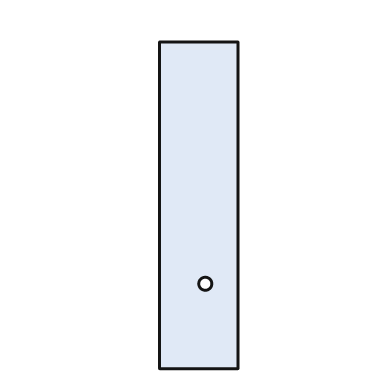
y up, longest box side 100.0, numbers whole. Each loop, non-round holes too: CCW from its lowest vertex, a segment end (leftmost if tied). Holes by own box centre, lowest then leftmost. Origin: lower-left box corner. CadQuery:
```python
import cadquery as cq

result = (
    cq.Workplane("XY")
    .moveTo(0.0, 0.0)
    .lineTo(24.0, 0.0)
    .lineTo(24.0, 100.0)
    .lineTo(0.0, 100.0)
    .close()
    .moveTo(14.0, 26.0)
    .circle(2.0)
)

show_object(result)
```